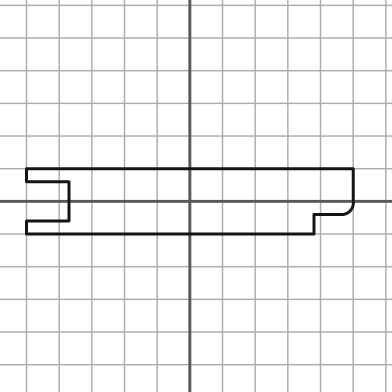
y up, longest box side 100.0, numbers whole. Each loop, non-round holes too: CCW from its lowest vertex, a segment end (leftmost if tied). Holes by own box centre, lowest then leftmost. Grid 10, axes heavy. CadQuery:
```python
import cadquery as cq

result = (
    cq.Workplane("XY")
    .moveTo(-50.0, -10.0)
    .lineTo(38.0, -10.0)
    .lineTo(38.0, -4.0)
    .lineTo(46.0, -4.0)
    .threePointArc((49.0, -3.0), (50.0, 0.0))
    .lineTo(50.0, 10.0)
    .lineTo(-50.0, 10.0)
    .lineTo(-50.0, 6.0)
    .lineTo(-37.0, 6.0)
    .lineTo(-37.0, -6.0)
    .lineTo(-50.0, -6.0)
    .close()
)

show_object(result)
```